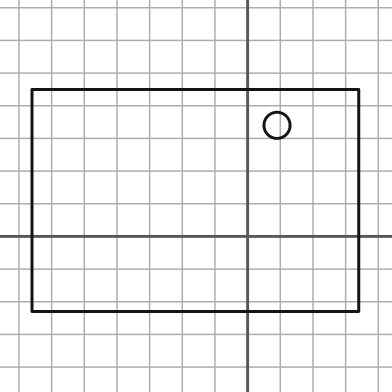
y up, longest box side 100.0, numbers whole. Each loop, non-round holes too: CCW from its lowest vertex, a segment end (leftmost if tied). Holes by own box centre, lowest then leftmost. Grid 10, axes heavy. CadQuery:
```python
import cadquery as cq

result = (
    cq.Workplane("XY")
    .moveTo(-66.0, -23.0)
    .lineTo(34.0, -23.0)
    .lineTo(34.0, 45.0)
    .lineTo(-66.0, 45.0)
    .close()
    .moveTo(9.0, 34.0)
    .circle(4.0)
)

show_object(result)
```